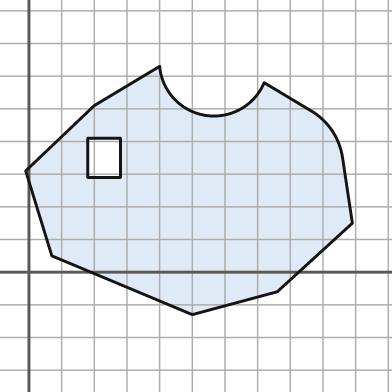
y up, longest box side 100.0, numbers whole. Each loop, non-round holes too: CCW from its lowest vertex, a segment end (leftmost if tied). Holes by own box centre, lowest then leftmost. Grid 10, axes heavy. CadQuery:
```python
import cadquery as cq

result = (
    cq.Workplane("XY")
    .moveTo(50.0, -13.0)
    .lineTo(76.0, -6.0)
    .lineTo(99.0, 15.0)
    .lineTo(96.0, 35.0)
    .threePointArc((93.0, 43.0), (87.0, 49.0))
    .lineTo(72.0, 58.0)
    .threePointArc((54.0, 48.0), (40.0, 63.0))
    .lineTo(20.0, 51.0)
    .lineTo(-1.0, 31.0)
    .lineTo(7.0, 5.0)
    .close()
    .moveTo(18.0, 29.0)
    .lineTo(28.0, 29.0)
    .lineTo(28.0, 41.0)
    .lineTo(18.0, 41.0)
    .close()
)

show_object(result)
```